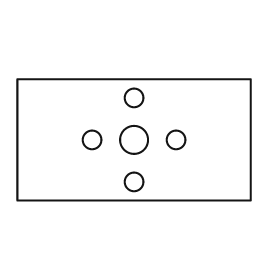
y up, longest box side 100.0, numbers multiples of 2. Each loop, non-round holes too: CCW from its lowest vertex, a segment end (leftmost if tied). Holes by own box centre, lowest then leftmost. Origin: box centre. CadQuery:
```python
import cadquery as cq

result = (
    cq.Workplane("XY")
    .moveTo(-50.0, -26.0)
    .lineTo(50.0, -26.0)
    .lineTo(50.0, 26.0)
    .lineTo(-50.0, 26.0)
    .close()
    .moveTo(0.0, -18.0)
    .circle(4.0)
    .moveTo(-18.0, 0.0)
    .circle(4.0)
    .moveTo(0.0, 0.0)
    .circle(6.0)
    .moveTo(18.0, 0.0)
    .circle(4.0)
    .moveTo(0.0, 18.0)
    .circle(4.0)
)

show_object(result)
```